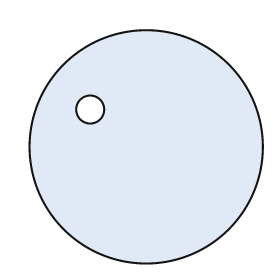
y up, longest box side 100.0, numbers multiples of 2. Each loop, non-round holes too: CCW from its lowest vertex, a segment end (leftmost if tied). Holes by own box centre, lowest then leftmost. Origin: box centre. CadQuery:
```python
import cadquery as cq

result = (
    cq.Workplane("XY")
    .moveTo(0.0, 0.0)
    .circle(50.0)
    .moveTo(-24.0, 16.0)
    .circle(6.0)
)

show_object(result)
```